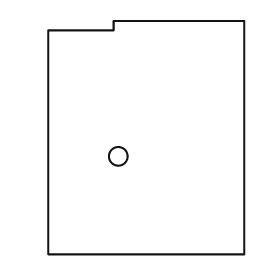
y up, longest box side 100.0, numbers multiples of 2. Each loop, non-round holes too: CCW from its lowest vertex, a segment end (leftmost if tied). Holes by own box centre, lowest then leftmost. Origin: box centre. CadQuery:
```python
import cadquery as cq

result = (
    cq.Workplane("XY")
    .moveTo(-42.0, -50.0)
    .lineTo(42.0, -50.0)
    .lineTo(42.0, 50.0)
    .lineTo(-14.0, 50.0)
    .lineTo(-14.0, 46.0)
    .lineTo(-42.0, 46.0)
    .close()
    .moveTo(-12.0, -8.0)
    .circle(4.0)
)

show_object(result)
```